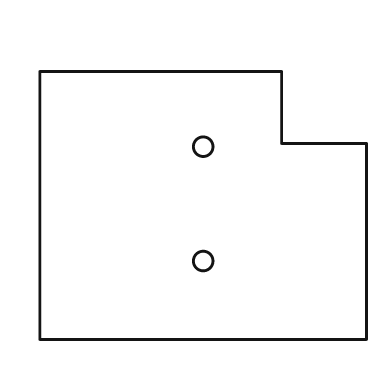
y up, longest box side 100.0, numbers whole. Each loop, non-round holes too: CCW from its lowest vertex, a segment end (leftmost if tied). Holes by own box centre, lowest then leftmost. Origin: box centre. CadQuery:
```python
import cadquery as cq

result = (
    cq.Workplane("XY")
    .moveTo(-50.0, -41.0)
    .lineTo(50.0, -41.0)
    .lineTo(50.0, 19.0)
    .lineTo(24.0, 19.0)
    .lineTo(24.0, 41.0)
    .lineTo(-50.0, 41.0)
    .close()
    .moveTo(0.0, -17.0)
    .circle(3.0)
    .moveTo(0.0, 18.0)
    .circle(3.0)
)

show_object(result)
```